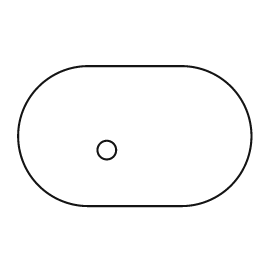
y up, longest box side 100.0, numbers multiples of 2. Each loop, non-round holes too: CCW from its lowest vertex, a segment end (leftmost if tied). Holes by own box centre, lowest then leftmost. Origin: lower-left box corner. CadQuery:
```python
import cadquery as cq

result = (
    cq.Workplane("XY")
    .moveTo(30.0, 0.0)
    .lineTo(70.0, 0.0)
    .threePointArc((100.0, 30.0), (70.0, 60.0))
    .lineTo(30.0, 60.0)
    .threePointArc((0.0, 30.0), (30.0, 0.0))
    .close()
    .moveTo(38.0, 24.0)
    .circle(4.0)
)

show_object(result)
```